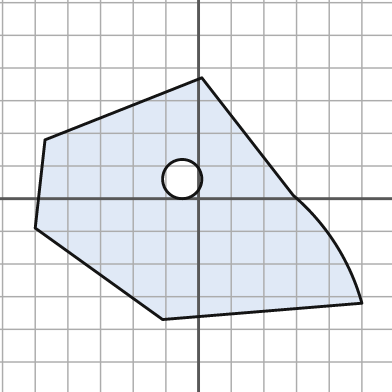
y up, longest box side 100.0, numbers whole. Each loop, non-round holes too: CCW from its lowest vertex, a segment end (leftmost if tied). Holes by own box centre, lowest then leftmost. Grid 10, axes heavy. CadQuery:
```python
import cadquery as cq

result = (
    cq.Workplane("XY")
    .moveTo(-11.0, -37.0)
    .lineTo(50.0, -32.0)
    .threePointArc((42.0, -14.0), (29.0, 1.0))
    .lineTo(1.0, 37.0)
    .lineTo(-47.0, 18.0)
    .lineTo(-50.0, -9.0)
    .close()
    .moveTo(-5.0, 6.0)
    .circle(6.0)
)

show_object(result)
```